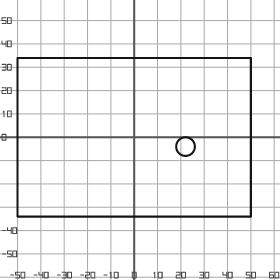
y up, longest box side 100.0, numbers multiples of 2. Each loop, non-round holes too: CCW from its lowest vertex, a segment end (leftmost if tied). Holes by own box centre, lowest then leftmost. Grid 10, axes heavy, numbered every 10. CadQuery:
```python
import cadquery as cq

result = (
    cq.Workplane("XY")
    .moveTo(-50.0, -34.0)
    .lineTo(50.0, -34.0)
    .lineTo(50.0, 34.0)
    .lineTo(-50.0, 34.0)
    .close()
    .moveTo(22.0, -4.0)
    .circle(4.0)
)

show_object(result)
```